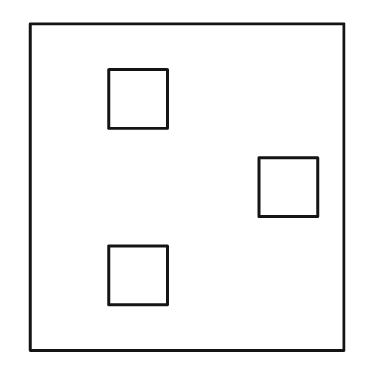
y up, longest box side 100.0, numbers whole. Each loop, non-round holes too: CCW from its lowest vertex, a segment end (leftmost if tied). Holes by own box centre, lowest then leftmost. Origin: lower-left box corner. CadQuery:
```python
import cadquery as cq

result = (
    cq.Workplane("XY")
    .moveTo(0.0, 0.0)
    .lineTo(96.0, 0.0)
    .lineTo(96.0, 100.0)
    .lineTo(0.0, 100.0)
    .close()
    .moveTo(24.0, 14.0)
    .lineTo(42.0, 14.0)
    .lineTo(42.0, 32.0)
    .lineTo(24.0, 32.0)
    .close()
    .moveTo(70.0, 41.0)
    .lineTo(88.0, 41.0)
    .lineTo(88.0, 59.0)
    .lineTo(70.0, 59.0)
    .close()
    .moveTo(24.0, 68.0)
    .lineTo(42.0, 68.0)
    .lineTo(42.0, 86.0)
    .lineTo(24.0, 86.0)
    .close()
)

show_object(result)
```